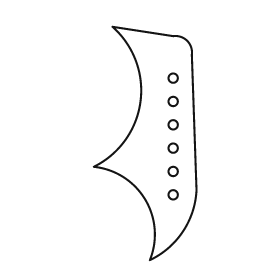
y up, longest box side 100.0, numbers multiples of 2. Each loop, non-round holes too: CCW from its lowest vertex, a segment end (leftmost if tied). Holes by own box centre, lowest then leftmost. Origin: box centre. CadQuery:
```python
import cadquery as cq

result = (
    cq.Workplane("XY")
    .moveTo(2.0, -50.0)
    .threePointArc((16.0, -38.0), (22.0, -20.0))
    .lineTo(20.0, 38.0)
    .threePointArc((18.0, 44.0), (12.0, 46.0))
    .lineTo(-14.0, 50.0)
    .threePointArc((-2.0, 18.0), (-22.0, -10.0))
    .threePointArc((0.0, -24.0), (2.0, -50.0))
    .close()
    .moveTo(12.0, -22.0)
    .circle(2.0)
    .moveTo(12.0, -12.0)
    .circle(2.0)
    .moveTo(12.0, -2.0)
    .circle(2.0)
    .moveTo(12.0, 8.0)
    .circle(2.0)
    .moveTo(12.0, 18.0)
    .circle(2.0)
    .moveTo(12.0, 28.0)
    .circle(2.0)
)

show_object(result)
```